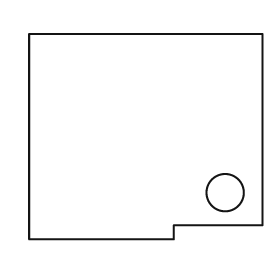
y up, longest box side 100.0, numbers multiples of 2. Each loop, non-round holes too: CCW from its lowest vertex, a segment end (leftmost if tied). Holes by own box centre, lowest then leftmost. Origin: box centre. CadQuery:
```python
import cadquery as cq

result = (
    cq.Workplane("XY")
    .moveTo(-50.0, -44.0)
    .lineTo(12.0, -44.0)
    .lineTo(12.0, -38.0)
    .lineTo(50.0, -38.0)
    .lineTo(50.0, 44.0)
    .lineTo(-50.0, 44.0)
    .close()
    .moveTo(34.0, -24.0)
    .circle(8.0)
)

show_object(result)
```